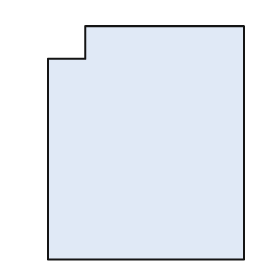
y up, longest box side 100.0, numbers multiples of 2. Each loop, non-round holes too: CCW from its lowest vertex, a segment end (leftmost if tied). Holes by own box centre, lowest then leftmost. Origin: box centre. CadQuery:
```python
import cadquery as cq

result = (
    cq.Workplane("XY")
    .moveTo(-42.0, -50.0)
    .lineTo(42.0, -50.0)
    .lineTo(42.0, 50.0)
    .lineTo(-26.0, 50.0)
    .lineTo(-26.0, 36.0)
    .lineTo(-42.0, 36.0)
    .close()
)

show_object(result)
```